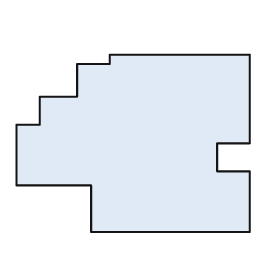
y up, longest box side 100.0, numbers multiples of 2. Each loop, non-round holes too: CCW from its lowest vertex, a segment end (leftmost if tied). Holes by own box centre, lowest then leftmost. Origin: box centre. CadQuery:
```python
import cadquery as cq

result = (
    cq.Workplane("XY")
    .moveTo(-18.0, -38.0)
    .lineTo(50.0, -38.0)
    .lineTo(50.0, -12.0)
    .lineTo(36.0, -12.0)
    .lineTo(36.0, 0.0)
    .lineTo(50.0, 0.0)
    .lineTo(50.0, 38.0)
    .lineTo(-10.0, 38.0)
    .lineTo(-10.0, 34.0)
    .lineTo(-24.0, 34.0)
    .lineTo(-24.0, 20.0)
    .lineTo(-40.0, 20.0)
    .lineTo(-40.0, 8.0)
    .lineTo(-50.0, 8.0)
    .lineTo(-50.0, -18.0)
    .lineTo(-18.0, -18.0)
    .close()
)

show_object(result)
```